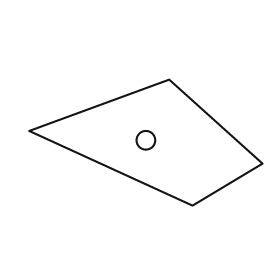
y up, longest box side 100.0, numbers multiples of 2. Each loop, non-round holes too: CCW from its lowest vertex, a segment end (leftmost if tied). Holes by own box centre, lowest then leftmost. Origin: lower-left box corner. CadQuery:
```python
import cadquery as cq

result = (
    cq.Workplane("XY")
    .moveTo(70.0, 0.0)
    .lineTo(100.0, 18.0)
    .lineTo(60.0, 54.0)
    .lineTo(0.0, 32.0)
    .close()
    .moveTo(50.0, 28.0)
    .circle(4.0)
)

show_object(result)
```